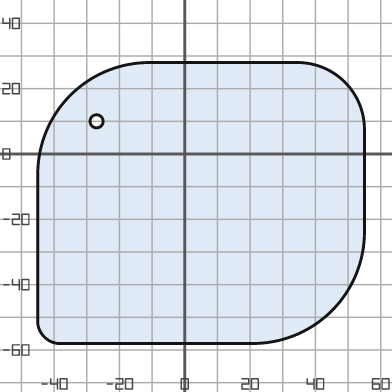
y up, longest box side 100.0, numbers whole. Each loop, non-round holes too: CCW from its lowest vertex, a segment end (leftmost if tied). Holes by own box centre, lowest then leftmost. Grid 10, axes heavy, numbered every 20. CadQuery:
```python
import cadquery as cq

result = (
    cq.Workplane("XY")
    .moveTo(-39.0, -58.0)
    .lineTo(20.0, -58.0)
    .threePointArc((45.0, -48.0), (55.0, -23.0))
    .lineTo(55.0, 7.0)
    .threePointArc((49.0, 22.0), (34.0, 28.0))
    .lineTo(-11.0, 28.0)
    .threePointArc((-35.0, 18.0), (-45.0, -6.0))
    .lineTo(-45.0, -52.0)
    .threePointArc((-43.0, -56.0), (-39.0, -58.0))
    .close()
    .moveTo(-27.0, 10.0)
    .circle(2.0)
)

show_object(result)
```